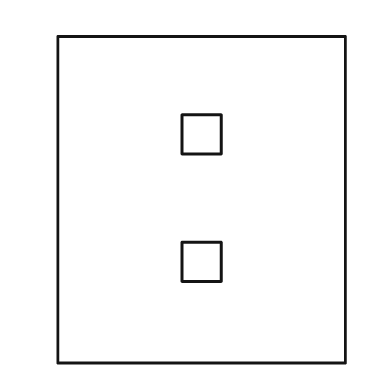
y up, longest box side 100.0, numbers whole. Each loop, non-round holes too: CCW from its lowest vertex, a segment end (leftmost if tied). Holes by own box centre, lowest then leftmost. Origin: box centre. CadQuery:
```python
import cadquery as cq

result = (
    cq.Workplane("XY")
    .moveTo(-44.0, -50.0)
    .lineTo(44.0, -50.0)
    .lineTo(44.0, 50.0)
    .lineTo(-44.0, 50.0)
    .close()
    .moveTo(-6.0, -25.0)
    .lineTo(6.0, -25.0)
    .lineTo(6.0, -13.0)
    .lineTo(-6.0, -13.0)
    .close()
    .moveTo(-6.0, 14.0)
    .lineTo(6.0, 14.0)
    .lineTo(6.0, 26.0)
    .lineTo(-6.0, 26.0)
    .close()
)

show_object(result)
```